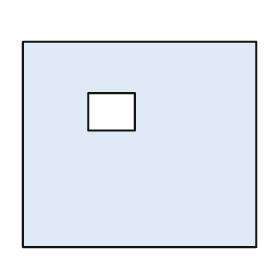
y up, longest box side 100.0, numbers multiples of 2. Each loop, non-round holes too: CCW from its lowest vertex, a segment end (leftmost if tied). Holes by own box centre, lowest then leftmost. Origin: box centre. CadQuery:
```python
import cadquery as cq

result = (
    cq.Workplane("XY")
    .moveTo(-50.0, -44.0)
    .lineTo(50.0, -44.0)
    .lineTo(50.0, 44.0)
    .lineTo(-50.0, 44.0)
    .close()
    .moveTo(-22.0, 6.0)
    .lineTo(-2.0, 6.0)
    .lineTo(-2.0, 22.0)
    .lineTo(-22.0, 22.0)
    .close()
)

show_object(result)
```